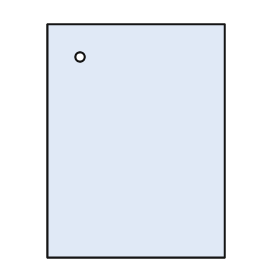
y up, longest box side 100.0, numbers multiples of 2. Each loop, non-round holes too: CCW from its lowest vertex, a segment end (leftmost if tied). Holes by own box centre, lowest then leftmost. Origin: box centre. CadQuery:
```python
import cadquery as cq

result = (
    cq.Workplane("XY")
    .moveTo(-38.0, -50.0)
    .lineTo(38.0, -50.0)
    .lineTo(38.0, 50.0)
    .lineTo(-38.0, 50.0)
    .close()
    .moveTo(-24.0, 36.0)
    .circle(2.0)
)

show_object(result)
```